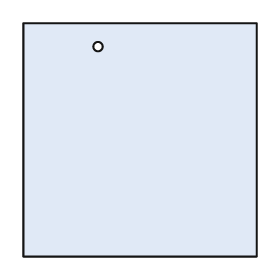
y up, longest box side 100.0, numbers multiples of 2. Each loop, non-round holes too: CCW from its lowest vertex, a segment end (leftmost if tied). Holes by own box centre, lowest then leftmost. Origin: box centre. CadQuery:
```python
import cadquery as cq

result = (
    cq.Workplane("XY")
    .moveTo(-50.0, -50.0)
    .lineTo(50.0, -50.0)
    .lineTo(50.0, 50.0)
    .lineTo(-50.0, 50.0)
    .close()
    .moveTo(-18.0, 40.0)
    .circle(2.0)
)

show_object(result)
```